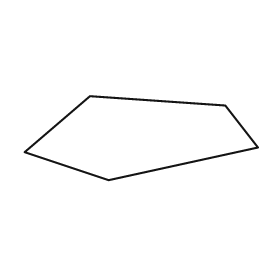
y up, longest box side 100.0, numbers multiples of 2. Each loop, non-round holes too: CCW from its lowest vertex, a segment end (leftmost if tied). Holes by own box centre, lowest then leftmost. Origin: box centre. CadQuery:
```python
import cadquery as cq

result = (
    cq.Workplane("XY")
    .moveTo(-14.0, -18.0)
    .lineTo(50.0, -4.0)
    .lineTo(36.0, 14.0)
    .lineTo(-22.0, 18.0)
    .lineTo(-50.0, -6.0)
    .close()
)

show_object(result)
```